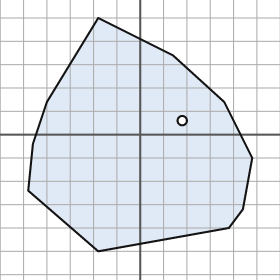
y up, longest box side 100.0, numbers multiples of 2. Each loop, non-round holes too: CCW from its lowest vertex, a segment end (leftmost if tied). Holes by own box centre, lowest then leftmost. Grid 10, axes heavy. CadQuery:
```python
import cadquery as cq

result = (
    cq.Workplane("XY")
    .moveTo(-18.0, -50.0)
    .lineTo(38.0, -40.0)
    .lineTo(44.0, -32.0)
    .lineTo(48.0, -10.0)
    .lineTo(36.0, 14.0)
    .lineTo(14.0, 34.0)
    .lineTo(-18.0, 50.0)
    .lineTo(-40.0, 14.0)
    .lineTo(-46.0, -4.0)
    .lineTo(-48.0, -24.0)
    .close()
    .moveTo(18.0, 6.0)
    .circle(2.0)
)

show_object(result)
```